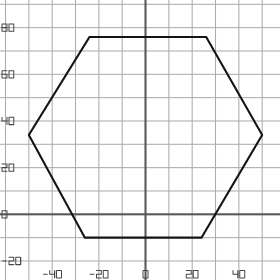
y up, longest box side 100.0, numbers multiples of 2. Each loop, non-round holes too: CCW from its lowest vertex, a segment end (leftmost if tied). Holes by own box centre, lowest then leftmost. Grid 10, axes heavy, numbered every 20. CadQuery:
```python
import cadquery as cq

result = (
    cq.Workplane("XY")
    .moveTo(-26.0, -10.0)
    .lineTo(24.0, -10.0)
    .lineTo(50.0, 34.0)
    .lineTo(26.0, 76.0)
    .lineTo(-24.0, 76.0)
    .lineTo(-50.0, 34.0)
    .close()
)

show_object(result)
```